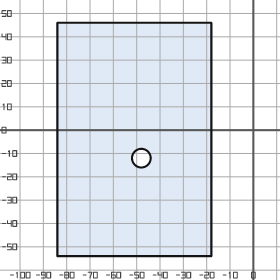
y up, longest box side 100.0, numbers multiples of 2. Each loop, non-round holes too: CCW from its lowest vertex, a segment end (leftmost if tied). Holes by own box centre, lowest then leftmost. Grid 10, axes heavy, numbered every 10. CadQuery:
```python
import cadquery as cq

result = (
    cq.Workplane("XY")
    .moveTo(-84.0, -54.0)
    .lineTo(-18.0, -54.0)
    .lineTo(-18.0, 46.0)
    .lineTo(-84.0, 46.0)
    .close()
    .moveTo(-48.0, -12.0)
    .circle(4.0)
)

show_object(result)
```